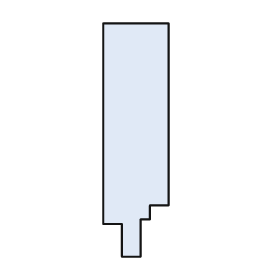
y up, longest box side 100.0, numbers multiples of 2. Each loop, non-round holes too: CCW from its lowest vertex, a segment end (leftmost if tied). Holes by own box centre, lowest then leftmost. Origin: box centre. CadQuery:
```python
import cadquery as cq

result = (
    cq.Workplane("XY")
    .moveTo(-6.0, -50.0)
    .lineTo(2.0, -50.0)
    .lineTo(2.0, -34.0)
    .lineTo(6.0, -34.0)
    .lineTo(6.0, -28.0)
    .lineTo(14.0, -28.0)
    .lineTo(14.0, 50.0)
    .lineTo(-14.0, 50.0)
    .lineTo(-14.0, -36.0)
    .lineTo(-6.0, -36.0)
    .close()
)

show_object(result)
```